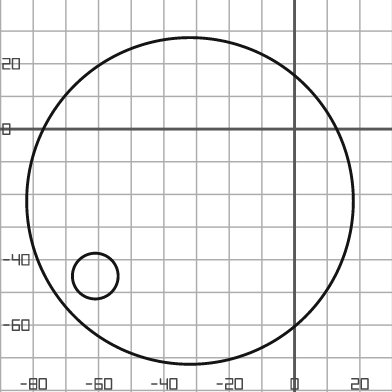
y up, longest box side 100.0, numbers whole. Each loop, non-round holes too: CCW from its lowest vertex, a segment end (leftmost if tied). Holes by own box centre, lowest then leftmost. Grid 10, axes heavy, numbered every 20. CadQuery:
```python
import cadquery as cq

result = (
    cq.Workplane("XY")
    .moveTo(-32.0, -22.0)
    .circle(50.0)
    .moveTo(-61.0, -45.0)
    .circle(7.0)
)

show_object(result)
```